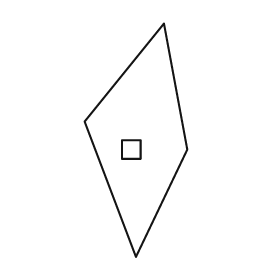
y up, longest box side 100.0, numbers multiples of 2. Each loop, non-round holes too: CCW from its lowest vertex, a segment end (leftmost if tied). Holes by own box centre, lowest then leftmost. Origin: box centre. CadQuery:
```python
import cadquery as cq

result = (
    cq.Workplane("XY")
    .moveTo(0.0, -50.0)
    .lineTo(22.0, -4.0)
    .lineTo(12.0, 50.0)
    .lineTo(-22.0, 8.0)
    .close()
    .moveTo(-6.0, -8.0)
    .lineTo(2.0, -8.0)
    .lineTo(2.0, 0.0)
    .lineTo(-6.0, 0.0)
    .close()
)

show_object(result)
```